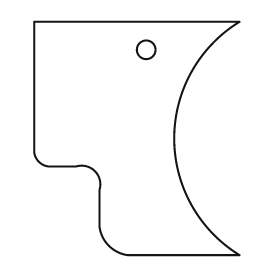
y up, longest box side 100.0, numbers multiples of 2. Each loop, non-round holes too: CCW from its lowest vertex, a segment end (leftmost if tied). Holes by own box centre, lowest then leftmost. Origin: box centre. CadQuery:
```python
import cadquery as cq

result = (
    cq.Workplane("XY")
    .moveTo(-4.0, -50.0)
    .lineTo(44.0, -50.0)
    .threePointArc((16.0, 0.0), (44.0, 50.0))
    .lineTo(-44.0, 50.0)
    .lineTo(-44.0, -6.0)
    .threePointArc((-42.0, -10.0), (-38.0, -12.0))
    .lineTo(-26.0, -12.0)
    .threePointArc((-18.0, -14.0), (-16.0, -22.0))
    .lineTo(-16.0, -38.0)
    .threePointArc((-12.0, -46.0), (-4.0, -50.0))
    .close()
    .moveTo(4.0, 38.0)
    .circle(4.0)
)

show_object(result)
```